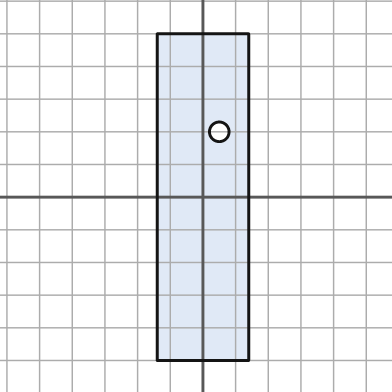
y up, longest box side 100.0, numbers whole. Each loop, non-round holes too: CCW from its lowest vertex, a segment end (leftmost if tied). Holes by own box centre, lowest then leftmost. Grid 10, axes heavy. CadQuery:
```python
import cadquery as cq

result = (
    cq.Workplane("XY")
    .moveTo(-14.0, -50.0)
    .lineTo(14.0, -50.0)
    .lineTo(14.0, 50.0)
    .lineTo(-14.0, 50.0)
    .close()
    .moveTo(5.0, 20.0)
    .circle(3.0)
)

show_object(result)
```